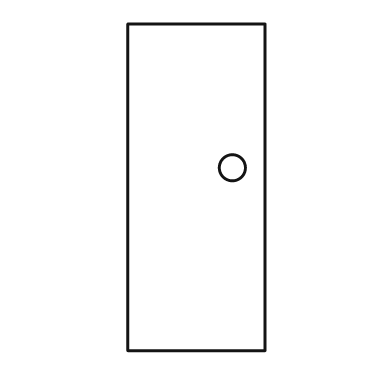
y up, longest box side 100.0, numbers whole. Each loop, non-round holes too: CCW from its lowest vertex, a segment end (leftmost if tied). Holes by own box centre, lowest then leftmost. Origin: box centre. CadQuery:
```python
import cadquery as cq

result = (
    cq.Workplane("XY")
    .moveTo(-21.0, -50.0)
    .lineTo(21.0, -50.0)
    .lineTo(21.0, 50.0)
    .lineTo(-21.0, 50.0)
    .close()
    .moveTo(11.0, 6.0)
    .circle(4.0)
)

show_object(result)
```